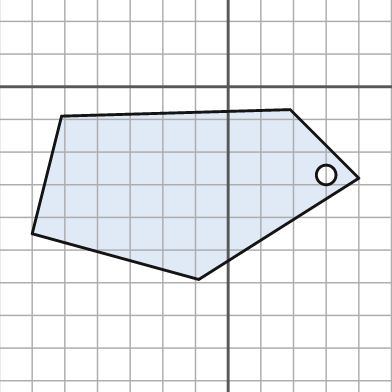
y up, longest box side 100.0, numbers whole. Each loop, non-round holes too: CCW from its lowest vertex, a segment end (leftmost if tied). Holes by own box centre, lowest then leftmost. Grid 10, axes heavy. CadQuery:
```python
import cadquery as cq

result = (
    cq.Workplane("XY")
    .moveTo(-9.0, -59.0)
    .lineTo(40.0, -28.0)
    .lineTo(19.0, -7.0)
    .lineTo(-51.0, -9.0)
    .lineTo(-60.0, -45.0)
    .close()
    .moveTo(30.0, -27.0)
    .circle(3.0)
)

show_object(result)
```